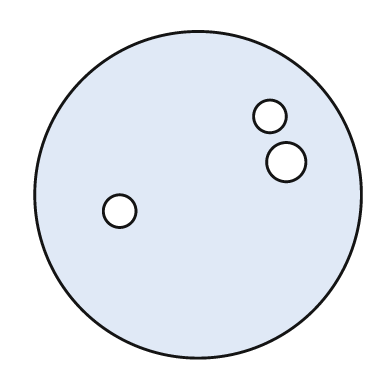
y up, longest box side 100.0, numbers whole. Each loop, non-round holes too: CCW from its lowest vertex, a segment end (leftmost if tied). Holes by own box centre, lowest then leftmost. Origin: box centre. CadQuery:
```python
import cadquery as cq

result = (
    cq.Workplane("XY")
    .moveTo(0.0, 0.0)
    .circle(50.0)
    .moveTo(-24.0, -5.0)
    .circle(5.0)
    .moveTo(27.0, 10.0)
    .circle(6.0)
    .moveTo(22.0, 24.0)
    .circle(5.0)
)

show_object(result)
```